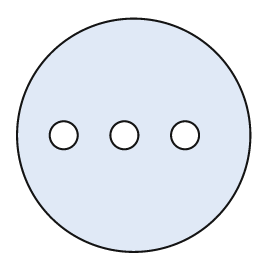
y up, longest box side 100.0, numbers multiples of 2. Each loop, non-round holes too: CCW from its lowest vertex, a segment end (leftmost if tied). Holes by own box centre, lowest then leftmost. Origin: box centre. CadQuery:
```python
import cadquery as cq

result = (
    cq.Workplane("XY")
    .moveTo(0.0, 0.0)
    .circle(50.0)
    .moveTo(-30.0, 0.0)
    .circle(6.0)
    .moveTo(-4.0, 0.0)
    .circle(6.0)
    .moveTo(22.0, 0.0)
    .circle(6.0)
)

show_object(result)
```